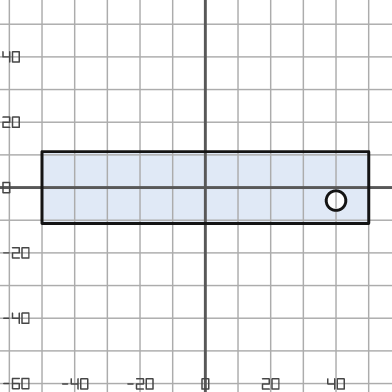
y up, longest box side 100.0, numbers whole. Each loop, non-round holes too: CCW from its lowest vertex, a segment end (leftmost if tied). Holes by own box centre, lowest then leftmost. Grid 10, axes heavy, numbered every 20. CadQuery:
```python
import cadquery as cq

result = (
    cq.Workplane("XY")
    .moveTo(-50.0, -11.0)
    .lineTo(50.0, -11.0)
    .lineTo(50.0, 11.0)
    .lineTo(-50.0, 11.0)
    .close()
    .moveTo(40.0, -4.0)
    .circle(3.0)
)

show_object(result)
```